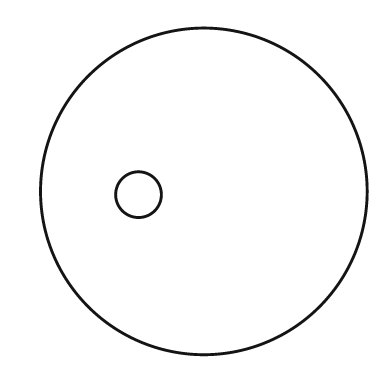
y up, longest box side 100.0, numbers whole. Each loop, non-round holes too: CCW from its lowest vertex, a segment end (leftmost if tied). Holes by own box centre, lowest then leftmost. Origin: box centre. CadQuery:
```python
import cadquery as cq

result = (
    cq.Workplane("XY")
    .moveTo(0.0, 0.0)
    .circle(50.0)
    .moveTo(-20.0, -1.0)
    .circle(7.0)
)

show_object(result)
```